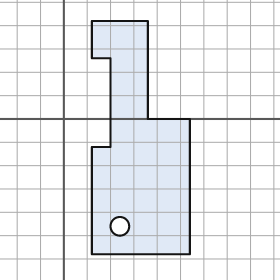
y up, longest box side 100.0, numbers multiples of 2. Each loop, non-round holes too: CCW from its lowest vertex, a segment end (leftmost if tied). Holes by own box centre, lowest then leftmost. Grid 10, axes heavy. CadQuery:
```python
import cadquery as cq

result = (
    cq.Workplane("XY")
    .moveTo(12.0, -58.0)
    .lineTo(54.0, -58.0)
    .lineTo(54.0, 0.0)
    .lineTo(36.0, 0.0)
    .lineTo(36.0, 42.0)
    .lineTo(12.0, 42.0)
    .lineTo(12.0, 26.0)
    .lineTo(20.0, 26.0)
    .lineTo(20.0, -12.0)
    .lineTo(12.0, -12.0)
    .close()
    .moveTo(24.0, -46.0)
    .circle(4.0)
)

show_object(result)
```